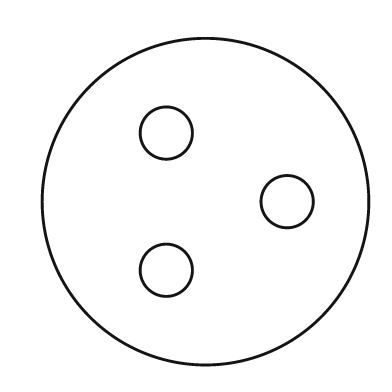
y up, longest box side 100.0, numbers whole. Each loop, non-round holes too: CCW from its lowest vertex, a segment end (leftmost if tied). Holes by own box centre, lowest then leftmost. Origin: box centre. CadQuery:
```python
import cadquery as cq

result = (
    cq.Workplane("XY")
    .moveTo(0.0, 0.0)
    .circle(50.0)
    .moveTo(-12.0, -21.0)
    .circle(8.0)
    .moveTo(25.0, 0.0)
    .circle(8.0)
    .moveTo(-12.0, 21.0)
    .circle(8.0)
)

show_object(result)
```